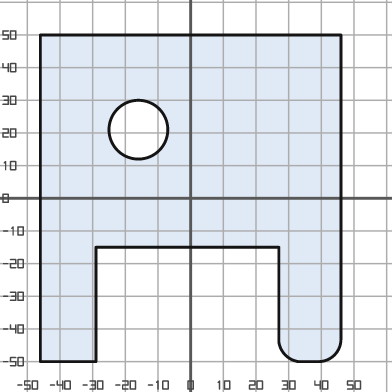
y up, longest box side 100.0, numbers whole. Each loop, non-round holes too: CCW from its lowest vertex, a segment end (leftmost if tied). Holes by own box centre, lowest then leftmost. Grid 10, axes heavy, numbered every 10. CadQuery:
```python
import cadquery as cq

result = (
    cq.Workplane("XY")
    .moveTo(-46.0, -50.0)
    .lineTo(-29.0, -50.0)
    .lineTo(-29.0, -15.0)
    .lineTo(27.0, -15.0)
    .lineTo(27.0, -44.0)
    .threePointArc((29.0, -48.0), (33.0, -50.0))
    .lineTo(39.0, -50.0)
    .threePointArc((44.0, -48.0), (46.0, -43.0))
    .lineTo(46.0, 50.0)
    .lineTo(-46.0, 50.0)
    .close()
    .moveTo(-16.0, 21.0)
    .circle(9.0)
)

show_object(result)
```